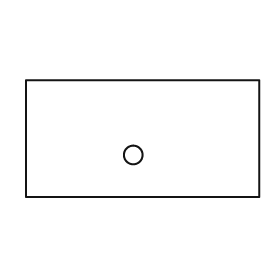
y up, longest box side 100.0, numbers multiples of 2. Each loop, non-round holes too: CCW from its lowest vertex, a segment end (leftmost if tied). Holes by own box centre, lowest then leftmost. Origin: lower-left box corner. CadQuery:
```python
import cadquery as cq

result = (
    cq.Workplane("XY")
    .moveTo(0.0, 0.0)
    .lineTo(100.0, 0.0)
    .lineTo(100.0, 50.0)
    .lineTo(0.0, 50.0)
    .close()
    .moveTo(46.0, 18.0)
    .circle(4.0)
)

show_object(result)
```